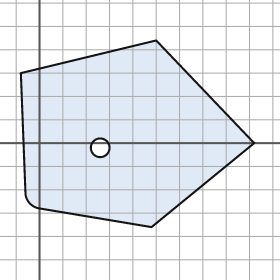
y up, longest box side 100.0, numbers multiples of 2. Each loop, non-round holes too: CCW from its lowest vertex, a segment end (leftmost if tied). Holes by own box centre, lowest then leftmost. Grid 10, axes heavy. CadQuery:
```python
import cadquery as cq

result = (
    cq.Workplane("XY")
    .moveTo(48.0, -36.0)
    .lineTo(92.0, 0.0)
    .lineTo(50.0, 44.0)
    .lineTo(-8.0, 30.0)
    .lineTo(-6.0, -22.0)
    .threePointArc((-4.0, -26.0), (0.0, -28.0))
    .close()
    .moveTo(26.0, -2.0)
    .circle(4.0)
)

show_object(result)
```